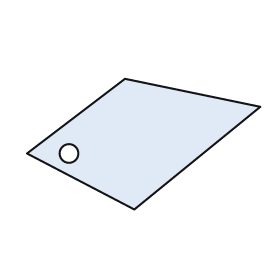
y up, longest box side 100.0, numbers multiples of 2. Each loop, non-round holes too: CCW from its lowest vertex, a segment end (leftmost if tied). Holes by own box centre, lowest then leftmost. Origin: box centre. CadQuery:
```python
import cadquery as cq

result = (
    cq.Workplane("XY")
    .moveTo(-4.0, -28.0)
    .lineTo(50.0, 16.0)
    .lineTo(-8.0, 28.0)
    .lineTo(-50.0, -4.0)
    .close()
    .moveTo(-32.0, -4.0)
    .circle(4.0)
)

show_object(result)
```